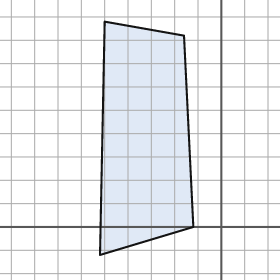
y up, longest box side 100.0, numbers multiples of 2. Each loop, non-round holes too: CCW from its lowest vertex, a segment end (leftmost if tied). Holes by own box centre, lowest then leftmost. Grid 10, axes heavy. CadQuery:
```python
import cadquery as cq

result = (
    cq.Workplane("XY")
    .moveTo(-52.0, -12.0)
    .lineTo(-12.0, 0.0)
    .lineTo(-16.0, 82.0)
    .lineTo(-50.0, 88.0)
    .close()
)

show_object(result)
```